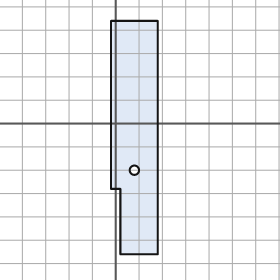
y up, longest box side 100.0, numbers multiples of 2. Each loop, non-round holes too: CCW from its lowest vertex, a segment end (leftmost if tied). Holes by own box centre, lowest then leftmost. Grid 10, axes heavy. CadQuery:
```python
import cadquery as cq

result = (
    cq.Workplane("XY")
    .moveTo(2.0, -56.0)
    .lineTo(18.0, -56.0)
    .lineTo(18.0, 44.0)
    .lineTo(-2.0, 44.0)
    .lineTo(-2.0, -28.0)
    .lineTo(2.0, -28.0)
    .close()
    .moveTo(8.0, -20.0)
    .circle(2.0)
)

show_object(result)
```